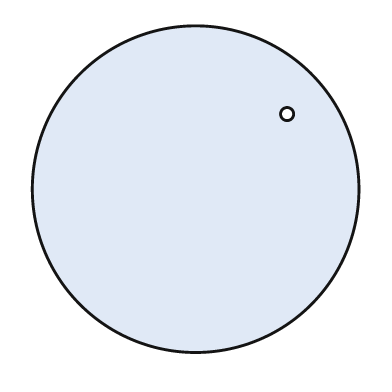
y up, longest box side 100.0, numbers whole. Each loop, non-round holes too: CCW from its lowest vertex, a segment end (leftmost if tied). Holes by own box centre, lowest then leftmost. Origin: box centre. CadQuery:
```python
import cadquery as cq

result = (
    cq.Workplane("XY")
    .moveTo(0.0, 0.0)
    .circle(50.0)
    .moveTo(28.0, 23.0)
    .circle(2.0)
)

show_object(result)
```